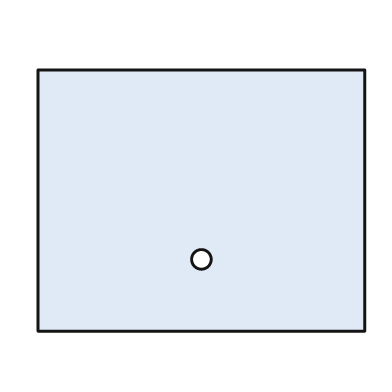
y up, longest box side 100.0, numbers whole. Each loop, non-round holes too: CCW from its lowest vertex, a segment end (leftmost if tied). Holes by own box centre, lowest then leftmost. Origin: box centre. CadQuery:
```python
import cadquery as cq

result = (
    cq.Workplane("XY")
    .moveTo(-50.0, -40.0)
    .lineTo(50.0, -40.0)
    .lineTo(50.0, 40.0)
    .lineTo(-50.0, 40.0)
    .close()
    .moveTo(0.0, -18.0)
    .circle(3.0)
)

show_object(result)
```